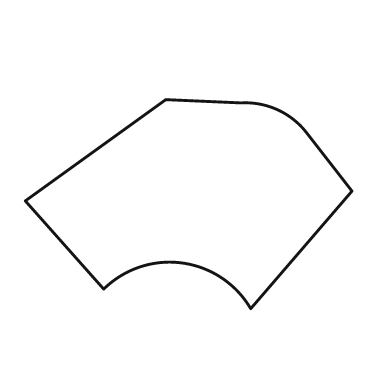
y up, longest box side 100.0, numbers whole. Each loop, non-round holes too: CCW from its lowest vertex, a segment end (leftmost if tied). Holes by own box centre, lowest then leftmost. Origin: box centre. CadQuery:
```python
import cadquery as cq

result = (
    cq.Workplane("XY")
    .moveTo(19.0, -32.0)
    .lineTo(50.0, 4.0)
    .lineTo(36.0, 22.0)
    .threePointArc((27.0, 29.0), (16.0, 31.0))
    .lineTo(-7.0, 32.0)
    .lineTo(-50.0, 1.0)
    .lineTo(-26.0, -26.0)
    .threePointArc((-2.0, -18.0), (19.0, -32.0))
    .close()
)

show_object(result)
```